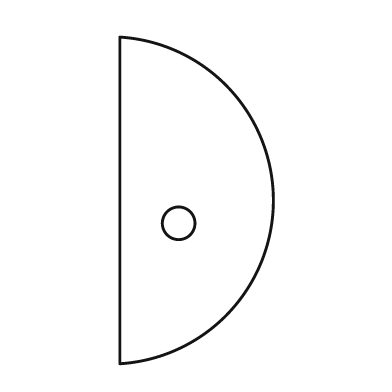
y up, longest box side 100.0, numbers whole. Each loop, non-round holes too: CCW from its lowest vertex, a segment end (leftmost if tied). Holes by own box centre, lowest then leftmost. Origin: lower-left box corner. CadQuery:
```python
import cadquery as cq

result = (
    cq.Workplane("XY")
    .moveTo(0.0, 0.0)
    .threePointArc((47.0, 50.0), (0.0, 100.0))
    .close()
    .moveTo(18.0, 43.0)
    .circle(5.0)
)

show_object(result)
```